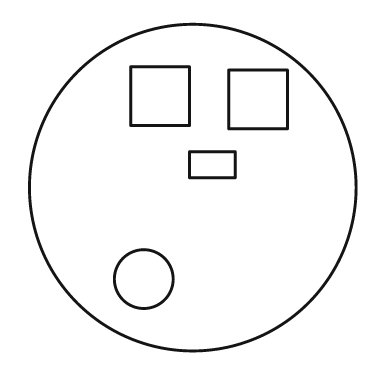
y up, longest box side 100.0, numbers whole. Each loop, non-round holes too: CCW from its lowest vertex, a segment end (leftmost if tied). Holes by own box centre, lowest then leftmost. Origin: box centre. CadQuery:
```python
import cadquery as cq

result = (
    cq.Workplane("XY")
    .moveTo(0.0, 0.0)
    .circle(50.0)
    .moveTo(-15.0, -28.0)
    .circle(9.0)
    .moveTo(-1.0, 3.0)
    .lineTo(13.0, 3.0)
    .lineTo(13.0, 11.0)
    .lineTo(-1.0, 11.0)
    .close()
    .moveTo(11.0, 18.0)
    .lineTo(29.0, 18.0)
    .lineTo(29.0, 36.0)
    .lineTo(11.0, 36.0)
    .close()
    .moveTo(-19.0, 19.0)
    .lineTo(-1.0, 19.0)
    .lineTo(-1.0, 37.0)
    .lineTo(-19.0, 37.0)
    .close()
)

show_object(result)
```